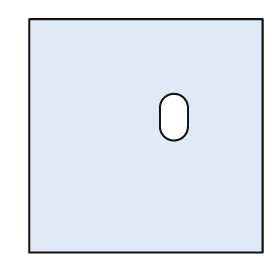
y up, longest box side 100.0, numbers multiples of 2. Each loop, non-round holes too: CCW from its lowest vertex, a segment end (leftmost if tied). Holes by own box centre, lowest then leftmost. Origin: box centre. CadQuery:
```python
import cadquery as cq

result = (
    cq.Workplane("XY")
    .moveTo(-50.0, -50.0)
    .lineTo(50.0, -50.0)
    .lineTo(50.0, 50.0)
    .lineTo(-50.0, 50.0)
    .close()
    .moveTo(6.0, 4.0)
    .threePointArc((12.0, -2.0), (18.0, 4.0))
    .lineTo(18.0, 12.0)
    .threePointArc((12.0, 18.0), (6.0, 12.0))
    .close()
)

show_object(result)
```